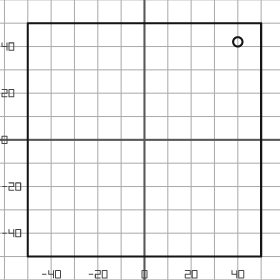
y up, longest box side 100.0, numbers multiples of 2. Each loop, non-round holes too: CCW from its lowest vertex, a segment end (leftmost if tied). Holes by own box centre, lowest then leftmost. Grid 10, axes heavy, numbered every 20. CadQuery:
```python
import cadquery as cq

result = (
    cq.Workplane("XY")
    .moveTo(-50.0, -50.0)
    .lineTo(50.0, -50.0)
    .lineTo(50.0, 50.0)
    .lineTo(-50.0, 50.0)
    .close()
    .moveTo(40.0, 42.0)
    .circle(2.0)
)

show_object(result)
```